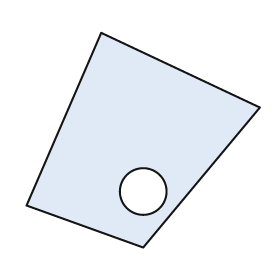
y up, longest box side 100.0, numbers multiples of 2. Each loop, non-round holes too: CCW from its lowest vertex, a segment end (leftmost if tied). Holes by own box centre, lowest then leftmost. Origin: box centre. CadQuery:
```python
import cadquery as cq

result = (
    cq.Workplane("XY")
    .moveTo(0.0, -46.0)
    .lineTo(50.0, 14.0)
    .lineTo(-18.0, 46.0)
    .lineTo(-50.0, -28.0)
    .close()
    .moveTo(0.0, -22.0)
    .circle(10.0)
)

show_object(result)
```